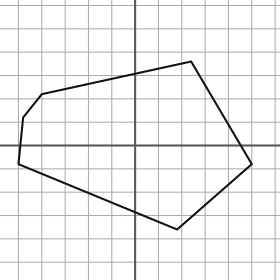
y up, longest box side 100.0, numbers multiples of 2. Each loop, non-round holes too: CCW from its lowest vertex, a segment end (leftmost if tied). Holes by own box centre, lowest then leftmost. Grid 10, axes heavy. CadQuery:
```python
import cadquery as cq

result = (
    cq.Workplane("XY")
    .moveTo(18.0, -36.0)
    .lineTo(50.0, -8.0)
    .lineTo(24.0, 36.0)
    .lineTo(-40.0, 22.0)
    .lineTo(-48.0, 12.0)
    .lineTo(-50.0, -8.0)
    .close()
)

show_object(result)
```